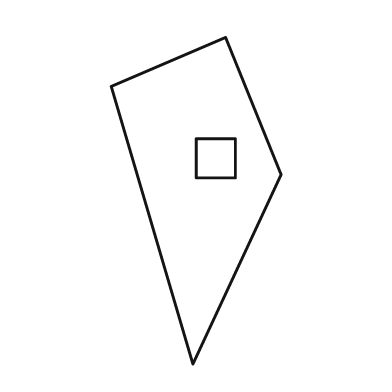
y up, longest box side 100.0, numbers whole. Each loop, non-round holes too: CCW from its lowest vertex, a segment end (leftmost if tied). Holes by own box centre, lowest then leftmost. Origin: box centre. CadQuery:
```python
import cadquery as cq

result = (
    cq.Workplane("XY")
    .moveTo(-1.0, -50.0)
    .lineTo(26.0, 8.0)
    .lineTo(9.0, 50.0)
    .lineTo(-26.0, 35.0)
    .close()
    .moveTo(0.0, 7.0)
    .lineTo(12.0, 7.0)
    .lineTo(12.0, 19.0)
    .lineTo(0.0, 19.0)
    .close()
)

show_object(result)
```